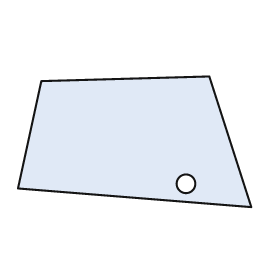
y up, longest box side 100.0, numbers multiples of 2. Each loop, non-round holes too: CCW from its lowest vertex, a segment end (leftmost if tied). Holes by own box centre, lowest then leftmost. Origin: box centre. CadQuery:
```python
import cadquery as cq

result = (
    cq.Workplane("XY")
    .moveTo(50.0, -28.0)
    .lineTo(32.0, 28.0)
    .lineTo(-40.0, 26.0)
    .lineTo(-50.0, -20.0)
    .close()
    .moveTo(22.0, -18.0)
    .circle(4.0)
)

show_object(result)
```